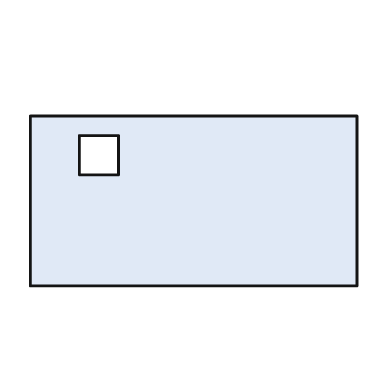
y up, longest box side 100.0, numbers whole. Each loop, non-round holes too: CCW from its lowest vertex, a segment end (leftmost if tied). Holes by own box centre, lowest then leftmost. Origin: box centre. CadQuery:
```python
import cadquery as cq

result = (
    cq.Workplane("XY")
    .moveTo(-50.0, -26.0)
    .lineTo(50.0, -26.0)
    .lineTo(50.0, 26.0)
    .lineTo(-50.0, 26.0)
    .close()
    .moveTo(-35.0, 8.0)
    .lineTo(-23.0, 8.0)
    .lineTo(-23.0, 20.0)
    .lineTo(-35.0, 20.0)
    .close()
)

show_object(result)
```